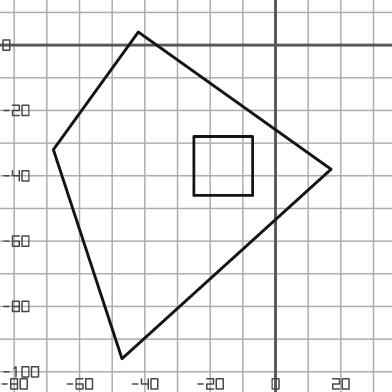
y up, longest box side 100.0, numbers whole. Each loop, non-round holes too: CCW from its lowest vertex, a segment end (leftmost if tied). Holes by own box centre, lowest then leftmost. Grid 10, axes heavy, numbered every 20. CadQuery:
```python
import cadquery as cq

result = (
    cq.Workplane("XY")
    .moveTo(-47.0, -96.0)
    .lineTo(17.0, -38.0)
    .lineTo(-42.0, 4.0)
    .lineTo(-68.0, -32.0)
    .close()
    .moveTo(-25.0, -46.0)
    .lineTo(-7.0, -46.0)
    .lineTo(-7.0, -28.0)
    .lineTo(-25.0, -28.0)
    .close()
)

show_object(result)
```